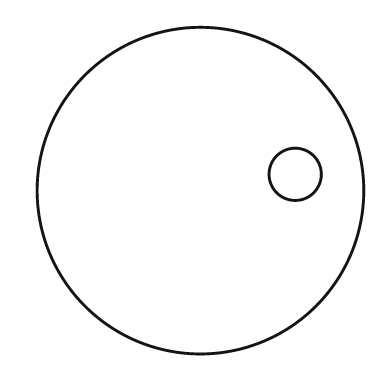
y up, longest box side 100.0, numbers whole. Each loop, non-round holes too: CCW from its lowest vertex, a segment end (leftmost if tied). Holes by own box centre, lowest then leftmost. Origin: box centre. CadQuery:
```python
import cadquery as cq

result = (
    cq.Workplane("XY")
    .moveTo(0.0, 0.0)
    .circle(50.0)
    .moveTo(29.0, 5.0)
    .circle(8.0)
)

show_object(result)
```